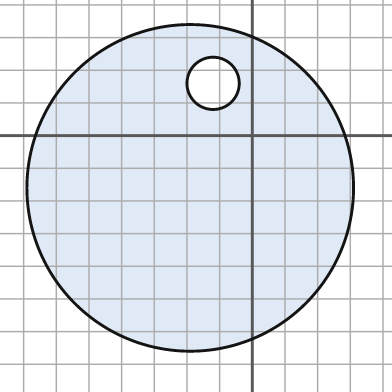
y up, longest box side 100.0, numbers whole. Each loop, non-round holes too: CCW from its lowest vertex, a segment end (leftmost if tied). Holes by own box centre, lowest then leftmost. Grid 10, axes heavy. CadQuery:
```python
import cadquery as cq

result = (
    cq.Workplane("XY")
    .moveTo(-19.0, -16.0)
    .circle(50.0)
    .moveTo(-12.0, 16.0)
    .circle(8.0)
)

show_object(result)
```